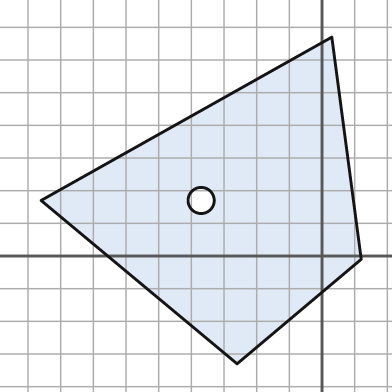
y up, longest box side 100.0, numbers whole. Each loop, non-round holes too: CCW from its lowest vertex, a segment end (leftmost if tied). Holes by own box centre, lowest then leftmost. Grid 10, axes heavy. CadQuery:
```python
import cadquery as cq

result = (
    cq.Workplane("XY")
    .moveTo(-26.0, -33.0)
    .lineTo(12.0, -1.0)
    .lineTo(3.0, 67.0)
    .lineTo(-86.0, 17.0)
    .close()
    .moveTo(-37.0, 17.0)
    .circle(4.0)
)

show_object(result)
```